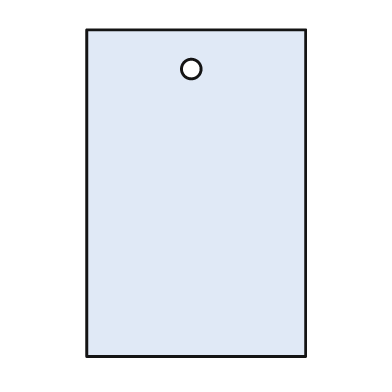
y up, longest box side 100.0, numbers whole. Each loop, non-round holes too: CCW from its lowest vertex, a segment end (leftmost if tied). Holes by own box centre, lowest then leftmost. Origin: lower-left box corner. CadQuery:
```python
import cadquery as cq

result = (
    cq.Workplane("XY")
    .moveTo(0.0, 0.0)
    .lineTo(67.0, 0.0)
    .lineTo(67.0, 100.0)
    .lineTo(0.0, 100.0)
    .close()
    .moveTo(32.0, 88.0)
    .circle(3.0)
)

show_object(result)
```